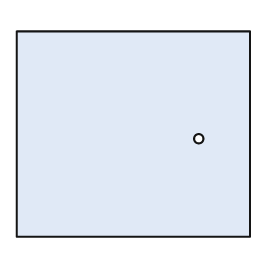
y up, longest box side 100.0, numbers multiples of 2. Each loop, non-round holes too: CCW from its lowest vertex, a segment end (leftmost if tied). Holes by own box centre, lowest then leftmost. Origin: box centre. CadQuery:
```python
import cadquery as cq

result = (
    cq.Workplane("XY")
    .moveTo(-50.0, -44.0)
    .lineTo(50.0, -44.0)
    .lineTo(50.0, 44.0)
    .lineTo(-50.0, 44.0)
    .close()
    .moveTo(28.0, -2.0)
    .circle(2.0)
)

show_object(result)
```